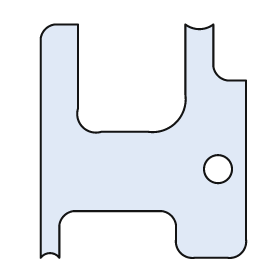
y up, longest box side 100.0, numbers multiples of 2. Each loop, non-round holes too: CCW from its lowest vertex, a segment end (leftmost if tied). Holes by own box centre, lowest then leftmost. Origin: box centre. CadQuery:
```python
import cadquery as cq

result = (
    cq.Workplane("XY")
    .moveTo(-44.0, -50.0)
    .threePointArc((-40.0, -48.0), (-36.0, -50.0))
    .lineTo(-36.0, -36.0)
    .threePointArc((-34.0, -32.0), (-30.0, -30.0))
    .lineTo(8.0, -30.0)
    .threePointArc((12.0, -32.0), (14.0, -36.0))
    .lineTo(14.0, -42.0)
    .threePointArc((16.0, -48.0), (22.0, -50.0))
    .lineTo(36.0, -50.0)
    .threePointArc((42.0, -48.0), (44.0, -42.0))
    .lineTo(44.0, 26.0)
    .lineTo(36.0, 26.0)
    .threePointArc((32.0, 28.0), (30.0, 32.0))
    .lineTo(30.0, 50.0)
    .threePointArc((24.0, 48.0), (18.0, 50.0))
    .lineTo(18.0, 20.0)
    .threePointArc((14.0, 8.0), (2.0, 4.0))
    .lineTo(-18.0, 4.0)
    .threePointArc((-26.0, 6.0), (-28.0, 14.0))
    .lineTo(-28.0, 50.0)
    .lineTo(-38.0, 50.0)
    .threePointArc((-42.0, 48.0), (-44.0, 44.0))
    .close()
    .moveTo(32.0, -12.0)
    .circle(6.0)
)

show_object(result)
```